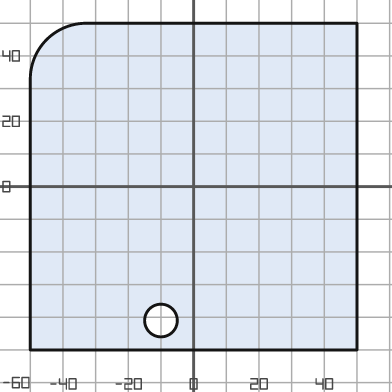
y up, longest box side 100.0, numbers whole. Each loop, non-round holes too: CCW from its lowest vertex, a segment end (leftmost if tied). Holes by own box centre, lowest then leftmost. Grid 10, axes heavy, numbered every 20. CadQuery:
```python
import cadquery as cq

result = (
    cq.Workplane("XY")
    .moveTo(-50.0, -50.0)
    .lineTo(50.0, -50.0)
    .lineTo(50.0, 50.0)
    .lineTo(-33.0, 50.0)
    .threePointArc((-45.0, 45.0), (-50.0, 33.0))
    .close()
    .moveTo(-10.0, -41.0)
    .circle(5.0)
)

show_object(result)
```